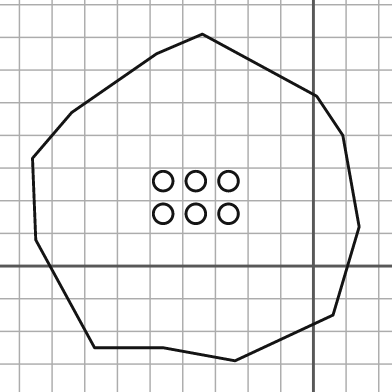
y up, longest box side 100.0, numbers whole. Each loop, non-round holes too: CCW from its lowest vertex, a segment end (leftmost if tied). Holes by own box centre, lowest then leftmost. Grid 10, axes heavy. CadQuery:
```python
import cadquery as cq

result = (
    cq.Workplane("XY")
    .moveTo(-24.0, -29.0)
    .lineTo(6.0, -15.0)
    .lineTo(14.0, 12.0)
    .lineTo(9.0, 40.0)
    .lineTo(1.0, 52.0)
    .lineTo(-34.0, 71.0)
    .lineTo(-48.0, 65.0)
    .lineTo(-74.0, 47.0)
    .lineTo(-86.0, 33.0)
    .lineTo(-85.0, 8.0)
    .lineTo(-67.0, -25.0)
    .lineTo(-46.0, -25.0)
    .close()
    .moveTo(-46.0, 16.0)
    .circle(3.0)
    .moveTo(-36.0, 16.0)
    .circle(3.0)
    .moveTo(-26.0, 16.0)
    .circle(3.0)
    .moveTo(-46.0, 26.0)
    .circle(3.0)
    .moveTo(-36.0, 26.0)
    .circle(3.0)
    .moveTo(-26.0, 26.0)
    .circle(3.0)
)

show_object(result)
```